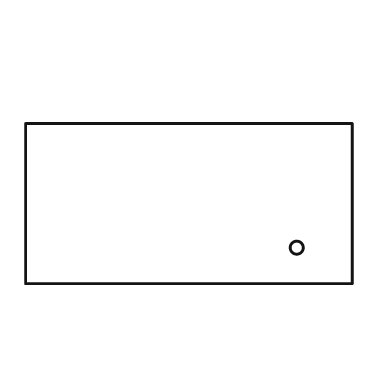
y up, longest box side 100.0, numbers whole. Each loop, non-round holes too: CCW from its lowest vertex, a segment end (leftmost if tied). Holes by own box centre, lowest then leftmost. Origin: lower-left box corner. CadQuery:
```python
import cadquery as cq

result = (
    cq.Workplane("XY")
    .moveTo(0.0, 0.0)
    .lineTo(100.0, 0.0)
    .lineTo(100.0, 49.0)
    .lineTo(0.0, 49.0)
    .close()
    .moveTo(83.0, 11.0)
    .circle(2.0)
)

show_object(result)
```